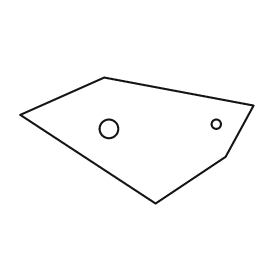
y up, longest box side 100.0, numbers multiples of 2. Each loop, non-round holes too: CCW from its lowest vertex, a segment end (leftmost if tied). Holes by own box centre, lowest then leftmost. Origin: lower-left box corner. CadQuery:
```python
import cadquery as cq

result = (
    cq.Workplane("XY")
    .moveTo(58.0, 0.0)
    .lineTo(88.0, 20.0)
    .lineTo(100.0, 42.0)
    .lineTo(36.0, 54.0)
    .lineTo(0.0, 38.0)
    .close()
    .moveTo(38.0, 32.0)
    .circle(4.0)
    .moveTo(84.0, 34.0)
    .circle(2.0)
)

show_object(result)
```